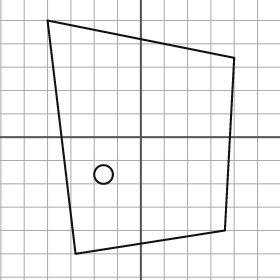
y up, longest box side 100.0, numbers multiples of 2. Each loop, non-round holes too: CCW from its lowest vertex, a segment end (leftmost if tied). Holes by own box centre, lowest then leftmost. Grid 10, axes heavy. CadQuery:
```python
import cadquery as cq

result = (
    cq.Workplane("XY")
    .moveTo(-28.0, -50.0)
    .lineTo(36.0, -40.0)
    .lineTo(40.0, 34.0)
    .lineTo(-40.0, 50.0)
    .close()
    .moveTo(-16.0, -16.0)
    .circle(4.0)
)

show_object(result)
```